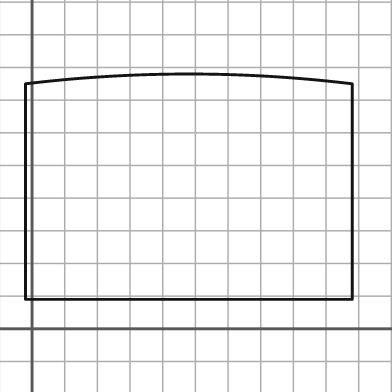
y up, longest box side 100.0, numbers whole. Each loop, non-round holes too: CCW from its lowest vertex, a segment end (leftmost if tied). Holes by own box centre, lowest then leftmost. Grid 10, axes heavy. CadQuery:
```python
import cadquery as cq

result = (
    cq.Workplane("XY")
    .moveTo(-2.0, 9.0)
    .lineTo(98.0, 9.0)
    .lineTo(98.0, 75.0)
    .threePointArc((48.0, 78.0), (-2.0, 75.0))
    .close()
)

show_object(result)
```